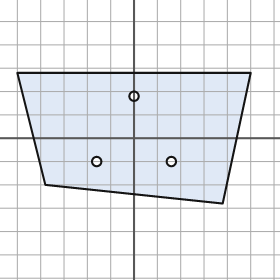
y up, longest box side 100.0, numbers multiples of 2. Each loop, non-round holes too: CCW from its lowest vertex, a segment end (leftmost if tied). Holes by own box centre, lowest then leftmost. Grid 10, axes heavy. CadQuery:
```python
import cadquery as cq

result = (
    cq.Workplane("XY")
    .moveTo(38.0, -28.0)
    .lineTo(50.0, 28.0)
    .lineTo(-50.0, 28.0)
    .lineTo(-38.0, -20.0)
    .close()
    .moveTo(-16.0, -10.0)
    .circle(2.0)
    .moveTo(16.0, -10.0)
    .circle(2.0)
    .moveTo(0.0, 18.0)
    .circle(2.0)
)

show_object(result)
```